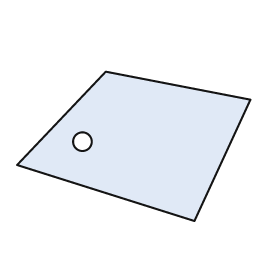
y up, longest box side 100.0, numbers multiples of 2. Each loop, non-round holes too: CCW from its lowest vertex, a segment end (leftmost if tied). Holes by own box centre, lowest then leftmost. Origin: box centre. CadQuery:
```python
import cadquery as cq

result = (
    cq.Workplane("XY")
    .moveTo(26.0, -32.0)
    .lineTo(50.0, 20.0)
    .lineTo(-12.0, 32.0)
    .lineTo(-50.0, -8.0)
    .close()
    .moveTo(-22.0, 2.0)
    .circle(4.0)
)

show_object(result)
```